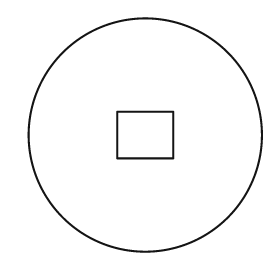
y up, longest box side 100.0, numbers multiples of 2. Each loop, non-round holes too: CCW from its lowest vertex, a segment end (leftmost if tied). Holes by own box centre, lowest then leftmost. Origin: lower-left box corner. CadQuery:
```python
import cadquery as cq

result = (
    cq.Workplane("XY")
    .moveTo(50.0, 50.0)
    .circle(50.0)
    .moveTo(38.0, 40.0)
    .lineTo(62.0, 40.0)
    .lineTo(62.0, 60.0)
    .lineTo(38.0, 60.0)
    .close()
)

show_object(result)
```